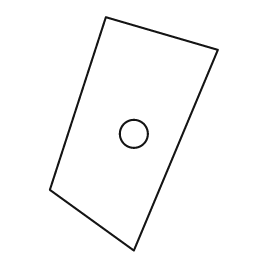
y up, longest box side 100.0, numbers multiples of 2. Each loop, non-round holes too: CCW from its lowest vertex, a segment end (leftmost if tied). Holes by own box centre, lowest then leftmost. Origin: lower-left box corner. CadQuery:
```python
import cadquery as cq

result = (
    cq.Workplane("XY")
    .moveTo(36.0, 0.0)
    .lineTo(72.0, 86.0)
    .lineTo(24.0, 100.0)
    .lineTo(0.0, 26.0)
    .close()
    .moveTo(36.0, 50.0)
    .circle(6.0)
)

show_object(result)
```